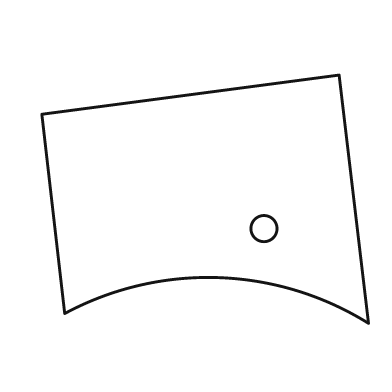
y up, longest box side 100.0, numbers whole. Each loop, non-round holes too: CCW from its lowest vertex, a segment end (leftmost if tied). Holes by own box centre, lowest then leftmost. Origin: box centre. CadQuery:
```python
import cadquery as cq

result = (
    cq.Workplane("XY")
    .moveTo(50.0, -38.0)
    .lineTo(41.0, 38.0)
    .lineTo(-50.0, 26.0)
    .lineTo(-43.0, -35.0)
    .threePointArc((4.0, -24.0), (50.0, -38.0))
    .close()
    .moveTo(18.0, -9.0)
    .circle(4.0)
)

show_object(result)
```